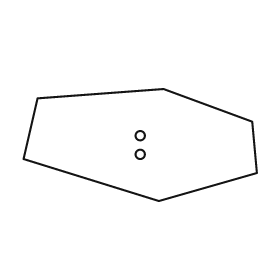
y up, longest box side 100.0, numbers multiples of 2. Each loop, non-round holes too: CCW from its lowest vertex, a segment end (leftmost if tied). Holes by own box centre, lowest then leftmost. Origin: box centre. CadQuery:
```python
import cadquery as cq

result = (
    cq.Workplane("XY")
    .moveTo(8.0, -24.0)
    .lineTo(50.0, -12.0)
    .lineTo(48.0, 10.0)
    .lineTo(10.0, 24.0)
    .lineTo(-44.0, 20.0)
    .lineTo(-50.0, -6.0)
    .close()
    .moveTo(0.0, -4.0)
    .circle(2.0)
    .moveTo(0.0, 4.0)
    .circle(2.0)
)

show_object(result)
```